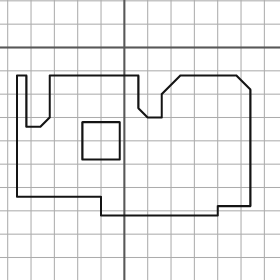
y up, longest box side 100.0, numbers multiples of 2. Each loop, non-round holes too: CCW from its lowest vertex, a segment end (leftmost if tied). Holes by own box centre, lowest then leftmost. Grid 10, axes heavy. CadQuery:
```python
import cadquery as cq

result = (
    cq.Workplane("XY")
    .moveTo(-10.0, -72.0)
    .lineTo(40.0, -72.0)
    .lineTo(40.0, -68.0)
    .lineTo(54.0, -68.0)
    .lineTo(54.0, -18.0)
    .lineTo(48.0, -12.0)
    .lineTo(24.0, -12.0)
    .lineTo(16.0, -20.0)
    .lineTo(16.0, -30.0)
    .lineTo(10.0, -30.0)
    .lineTo(6.0, -26.0)
    .lineTo(6.0, -12.0)
    .lineTo(-32.0, -12.0)
    .lineTo(-32.0, -30.0)
    .lineTo(-36.0, -34.0)
    .lineTo(-42.0, -34.0)
    .lineTo(-42.0, -12.0)
    .lineTo(-46.0, -12.0)
    .lineTo(-46.0, -64.0)
    .lineTo(-10.0, -64.0)
    .close()
    .moveTo(-18.0, -48.0)
    .lineTo(-2.0, -48.0)
    .lineTo(-2.0, -32.0)
    .lineTo(-18.0, -32.0)
    .close()
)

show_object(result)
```